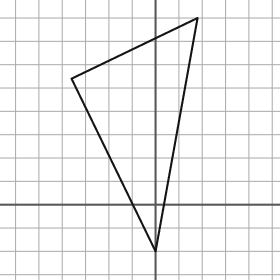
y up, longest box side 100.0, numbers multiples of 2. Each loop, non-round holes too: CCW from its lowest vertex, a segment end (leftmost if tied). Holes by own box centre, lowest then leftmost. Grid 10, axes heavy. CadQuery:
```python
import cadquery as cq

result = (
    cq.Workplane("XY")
    .moveTo(0.0, -20.0)
    .lineTo(18.0, 80.0)
    .lineTo(-36.0, 54.0)
    .close()
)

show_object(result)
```